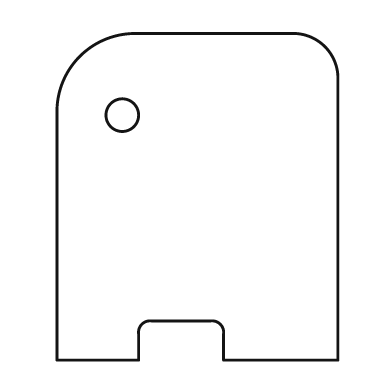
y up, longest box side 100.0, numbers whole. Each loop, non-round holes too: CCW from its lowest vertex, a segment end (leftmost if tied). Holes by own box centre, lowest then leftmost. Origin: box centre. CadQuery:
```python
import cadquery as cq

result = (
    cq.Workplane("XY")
    .moveTo(-43.0, -50.0)
    .lineTo(-18.0, -50.0)
    .lineTo(-18.0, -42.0)
    .threePointArc((-17.0, -39.0), (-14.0, -38.0))
    .lineTo(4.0, -38.0)
    .threePointArc((7.0, -39.0), (8.0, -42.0))
    .lineTo(8.0, -50.0)
    .lineTo(43.0, -50.0)
    .lineTo(43.0, 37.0)
    .threePointArc((39.0, 46.0), (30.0, 50.0))
    .lineTo(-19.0, 50.0)
    .threePointArc((-36.0, 43.0), (-43.0, 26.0))
    .close()
    .moveTo(-23.0, 25.0)
    .circle(5.0)
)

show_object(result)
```